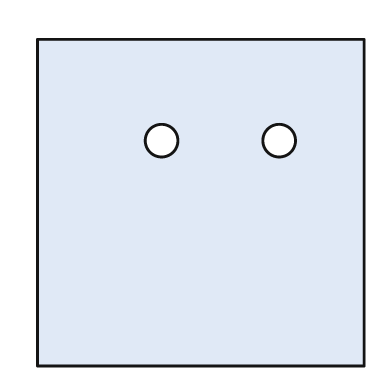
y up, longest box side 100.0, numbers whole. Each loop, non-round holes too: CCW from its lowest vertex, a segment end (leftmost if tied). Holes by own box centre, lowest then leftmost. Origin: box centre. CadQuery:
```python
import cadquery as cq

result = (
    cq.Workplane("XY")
    .moveTo(-50.0, -50.0)
    .lineTo(50.0, -50.0)
    .lineTo(50.0, 50.0)
    .lineTo(-50.0, 50.0)
    .close()
    .moveTo(-12.0, 19.0)
    .circle(5.0)
    .moveTo(24.0, 19.0)
    .circle(5.0)
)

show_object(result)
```